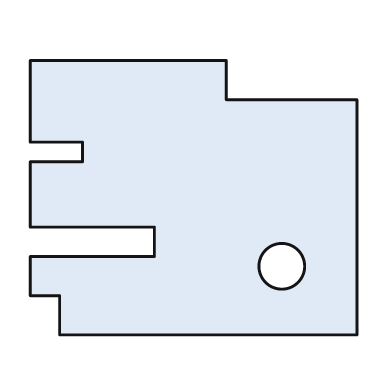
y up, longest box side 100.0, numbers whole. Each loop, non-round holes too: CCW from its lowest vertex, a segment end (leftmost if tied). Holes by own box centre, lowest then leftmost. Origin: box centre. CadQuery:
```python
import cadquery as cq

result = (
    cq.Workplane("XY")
    .moveTo(-41.0, -42.0)
    .lineTo(50.0, -42.0)
    .lineTo(50.0, 30.0)
    .lineTo(10.0, 30.0)
    .lineTo(10.0, 42.0)
    .lineTo(-50.0, 42.0)
    .lineTo(-50.0, 17.0)
    .lineTo(-34.0, 17.0)
    .lineTo(-34.0, 11.0)
    .lineTo(-50.0, 11.0)
    .lineTo(-50.0, -9.0)
    .lineTo(-12.0, -9.0)
    .lineTo(-12.0, -18.0)
    .lineTo(-50.0, -18.0)
    .lineTo(-50.0, -30.0)
    .lineTo(-41.0, -30.0)
    .close()
    .moveTo(27.0, -21.0)
    .circle(7.0)
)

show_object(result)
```